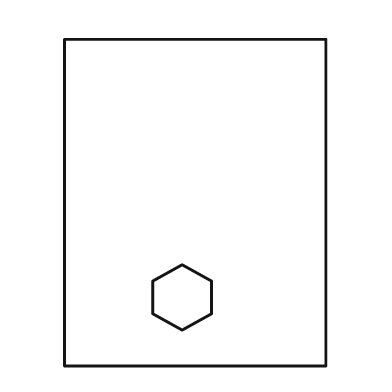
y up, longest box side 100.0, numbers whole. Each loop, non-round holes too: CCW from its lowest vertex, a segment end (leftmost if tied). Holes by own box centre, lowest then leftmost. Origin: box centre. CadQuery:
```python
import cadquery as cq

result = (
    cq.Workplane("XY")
    .moveTo(-40.0, -50.0)
    .lineTo(40.0, -50.0)
    .lineTo(40.0, 50.0)
    .lineTo(-40.0, 50.0)
    .close()
    .moveTo(-4.0, -39.0)
    .lineTo(5.0, -34.0)
    .lineTo(5.0, -24.0)
    .lineTo(-4.0, -19.0)
    .lineTo(-13.0, -24.0)
    .lineTo(-13.0, -34.0)
    .close()
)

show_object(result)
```